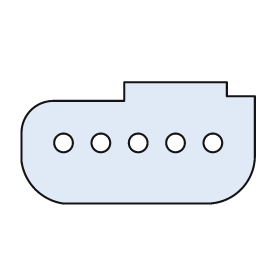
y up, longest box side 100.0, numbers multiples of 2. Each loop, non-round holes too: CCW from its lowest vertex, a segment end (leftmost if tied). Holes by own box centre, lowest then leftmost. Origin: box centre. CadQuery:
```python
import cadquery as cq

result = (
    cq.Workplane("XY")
    .moveTo(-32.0, -26.0)
    .lineTo(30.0, -26.0)
    .threePointArc((44.0, -20.0), (50.0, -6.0))
    .lineTo(50.0, 20.0)
    .lineTo(38.0, 20.0)
    .lineTo(38.0, 26.0)
    .lineTo(-6.0, 26.0)
    .lineTo(-6.0, 18.0)
    .lineTo(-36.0, 18.0)
    .threePointArc((-46.0, 14.0), (-50.0, 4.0))
    .lineTo(-50.0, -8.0)
    .threePointArc((-44.0, -20.0), (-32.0, -26.0))
    .close()
    .moveTo(-32.0, 0.0)
    .circle(4.0)
    .moveTo(-16.0, 0.0)
    .circle(4.0)
    .moveTo(0.0, 0.0)
    .circle(4.0)
    .moveTo(16.0, 0.0)
    .circle(4.0)
    .moveTo(32.0, 0.0)
    .circle(4.0)
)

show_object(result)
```